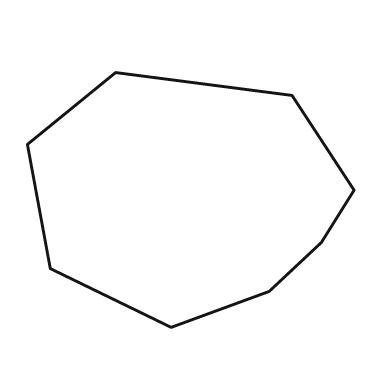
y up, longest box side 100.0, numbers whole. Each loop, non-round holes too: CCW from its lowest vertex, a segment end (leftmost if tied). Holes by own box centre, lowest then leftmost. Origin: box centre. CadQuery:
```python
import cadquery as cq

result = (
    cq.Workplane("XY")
    .moveTo(-6.0, -39.0)
    .lineTo(24.0, -28.0)
    .lineTo(40.0, -13.0)
    .lineTo(50.0, 3.0)
    .lineTo(31.0, 32.0)
    .lineTo(-23.0, 39.0)
    .lineTo(-50.0, 17.0)
    .lineTo(-43.0, -21.0)
    .close()
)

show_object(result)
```